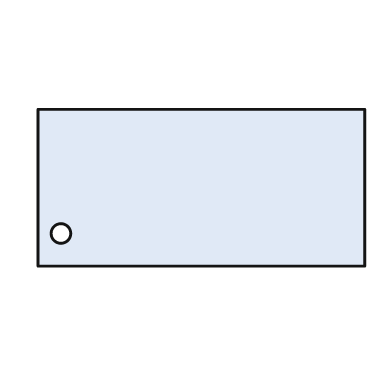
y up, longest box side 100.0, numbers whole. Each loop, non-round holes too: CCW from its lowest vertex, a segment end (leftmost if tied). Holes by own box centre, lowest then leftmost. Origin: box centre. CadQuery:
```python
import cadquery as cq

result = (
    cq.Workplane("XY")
    .moveTo(-50.0, -24.0)
    .lineTo(50.0, -24.0)
    .lineTo(50.0, 24.0)
    .lineTo(-50.0, 24.0)
    .close()
    .moveTo(-43.0, -14.0)
    .circle(3.0)
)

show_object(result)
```